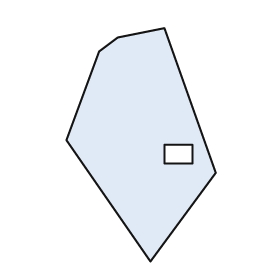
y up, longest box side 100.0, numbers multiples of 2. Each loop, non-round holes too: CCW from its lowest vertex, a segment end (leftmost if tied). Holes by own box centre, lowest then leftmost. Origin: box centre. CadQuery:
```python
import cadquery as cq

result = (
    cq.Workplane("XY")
    .moveTo(4.0, -50.0)
    .lineTo(32.0, -12.0)
    .lineTo(10.0, 50.0)
    .lineTo(-10.0, 46.0)
    .lineTo(-18.0, 40.0)
    .lineTo(-32.0, 2.0)
    .close()
    .moveTo(10.0, -8.0)
    .lineTo(22.0, -8.0)
    .lineTo(22.0, 0.0)
    .lineTo(10.0, 0.0)
    .close()
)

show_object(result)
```